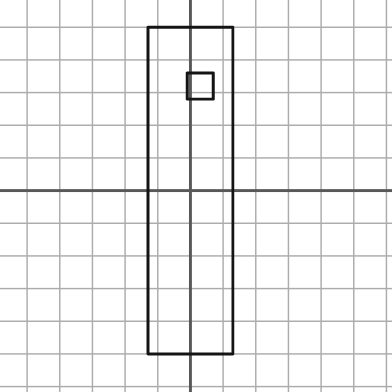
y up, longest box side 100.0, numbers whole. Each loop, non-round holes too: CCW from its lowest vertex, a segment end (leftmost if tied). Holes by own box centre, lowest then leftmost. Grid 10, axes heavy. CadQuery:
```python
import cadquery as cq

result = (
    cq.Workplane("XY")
    .moveTo(-13.0, -50.0)
    .lineTo(13.0, -50.0)
    .lineTo(13.0, 50.0)
    .lineTo(-13.0, 50.0)
    .close()
    .moveTo(-1.0, 28.0)
    .lineTo(7.0, 28.0)
    .lineTo(7.0, 36.0)
    .lineTo(-1.0, 36.0)
    .close()
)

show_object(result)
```